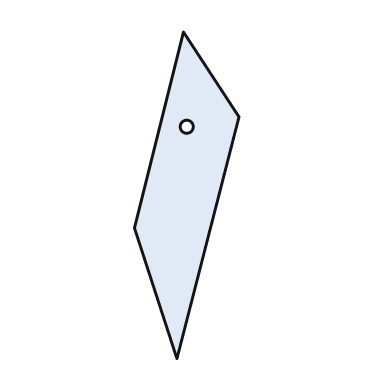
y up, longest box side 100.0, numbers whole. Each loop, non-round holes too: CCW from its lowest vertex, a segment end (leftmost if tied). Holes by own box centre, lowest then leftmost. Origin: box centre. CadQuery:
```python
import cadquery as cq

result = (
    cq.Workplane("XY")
    .moveTo(-3.0, -50.0)
    .lineTo(16.0, 24.0)
    .lineTo(-1.0, 50.0)
    .lineTo(-16.0, -10.0)
    .close()
    .moveTo(0.0, 21.0)
    .circle(2.0)
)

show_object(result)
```